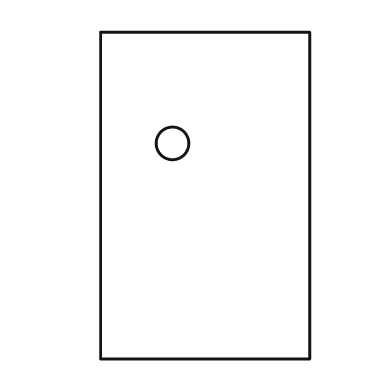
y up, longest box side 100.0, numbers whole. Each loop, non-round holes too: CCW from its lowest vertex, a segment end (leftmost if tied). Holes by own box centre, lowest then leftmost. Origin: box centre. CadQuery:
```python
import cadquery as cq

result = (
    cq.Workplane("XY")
    .moveTo(-32.0, -50.0)
    .lineTo(32.0, -50.0)
    .lineTo(32.0, 50.0)
    .lineTo(-32.0, 50.0)
    .close()
    .moveTo(-10.0, 16.0)
    .circle(5.0)
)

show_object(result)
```